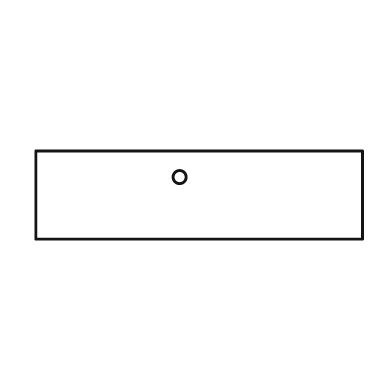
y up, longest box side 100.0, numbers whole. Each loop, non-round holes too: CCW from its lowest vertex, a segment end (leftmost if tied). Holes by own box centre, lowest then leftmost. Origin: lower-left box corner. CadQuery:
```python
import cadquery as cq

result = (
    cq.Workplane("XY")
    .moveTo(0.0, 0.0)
    .lineTo(100.0, 0.0)
    .lineTo(100.0, 27.0)
    .lineTo(0.0, 27.0)
    .close()
    .moveTo(44.0, 19.0)
    .circle(2.0)
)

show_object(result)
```